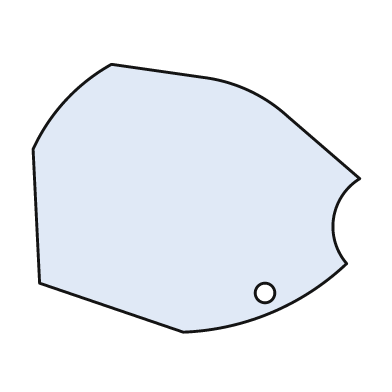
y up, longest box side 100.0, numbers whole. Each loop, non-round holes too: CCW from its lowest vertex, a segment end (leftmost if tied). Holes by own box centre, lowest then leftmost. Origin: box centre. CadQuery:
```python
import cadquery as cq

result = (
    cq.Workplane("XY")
    .moveTo(-4.0, -41.0)
    .threePointArc((23.0, -35.0), (46.0, -20.0))
    .threePointArc((42.0, -6.0), (50.0, 6.0))
    .lineTo(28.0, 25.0)
    .threePointArc((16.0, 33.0), (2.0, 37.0))
    .lineTo(-26.0, 41.0)
    .threePointArc((-40.0, 30.0), (-50.0, 15.0))
    .lineTo(-48.0, -26.0)
    .close()
    .moveTo(21.0, -29.0)
    .circle(3.0)
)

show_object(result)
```